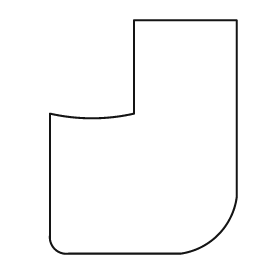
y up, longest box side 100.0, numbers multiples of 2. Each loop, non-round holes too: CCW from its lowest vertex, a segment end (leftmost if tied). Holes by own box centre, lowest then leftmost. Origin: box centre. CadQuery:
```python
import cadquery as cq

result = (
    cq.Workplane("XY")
    .moveTo(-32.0, -50.0)
    .lineTo(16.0, -50.0)
    .threePointArc((32.0, -42.0), (40.0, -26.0))
    .lineTo(40.0, 50.0)
    .lineTo(-4.0, 50.0)
    .lineTo(-4.0, 10.0)
    .threePointArc((-22.0, 8.0), (-40.0, 10.0))
    .lineTo(-40.0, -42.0)
    .threePointArc((-38.0, -48.0), (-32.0, -50.0))
    .close()
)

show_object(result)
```